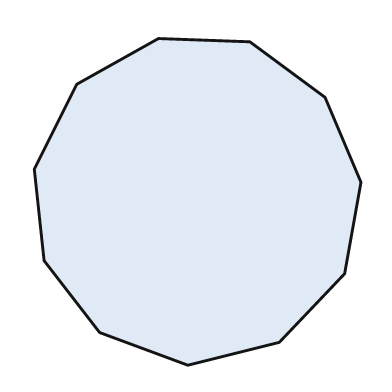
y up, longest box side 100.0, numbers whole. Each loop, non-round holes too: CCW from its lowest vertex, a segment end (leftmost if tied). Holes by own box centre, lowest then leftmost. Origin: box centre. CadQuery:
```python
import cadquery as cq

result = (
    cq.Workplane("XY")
    .moveTo(-3.0, -50.0)
    .lineTo(25.0, -43.0)
    .lineTo(45.0, -22.0)
    .lineTo(50.0, 6.0)
    .lineTo(39.0, 32.0)
    .lineTo(16.0, 49.0)
    .lineTo(-12.0, 50.0)
    .lineTo(-37.0, 36.0)
    .lineTo(-50.0, 10.0)
    .lineTo(-47.0, -18.0)
    .lineTo(-30.0, -40.0)
    .close()
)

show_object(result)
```